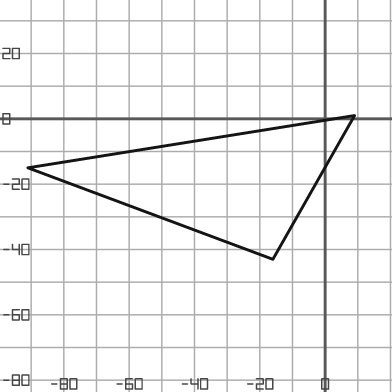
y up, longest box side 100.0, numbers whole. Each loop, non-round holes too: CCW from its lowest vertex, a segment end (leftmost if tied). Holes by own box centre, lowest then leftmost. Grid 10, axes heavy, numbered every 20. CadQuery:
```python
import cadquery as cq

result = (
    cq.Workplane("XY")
    .moveTo(-16.0, -43.0)
    .lineTo(9.0, 1.0)
    .lineTo(-91.0, -15.0)
    .close()
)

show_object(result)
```